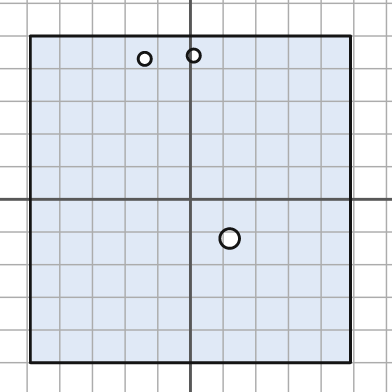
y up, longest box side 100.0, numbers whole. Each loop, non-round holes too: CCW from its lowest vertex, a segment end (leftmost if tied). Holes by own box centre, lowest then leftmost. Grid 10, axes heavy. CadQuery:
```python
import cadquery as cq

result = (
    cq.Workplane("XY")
    .moveTo(-49.0, -50.0)
    .lineTo(49.0, -50.0)
    .lineTo(49.0, 50.0)
    .lineTo(-49.0, 50.0)
    .close()
    .moveTo(12.0, -12.0)
    .circle(3.0)
    .moveTo(-14.0, 43.0)
    .circle(2.0)
    .moveTo(1.0, 44.0)
    .circle(2.0)
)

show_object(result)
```